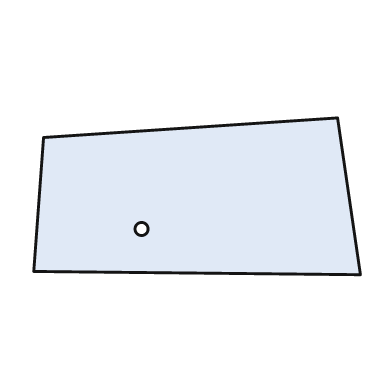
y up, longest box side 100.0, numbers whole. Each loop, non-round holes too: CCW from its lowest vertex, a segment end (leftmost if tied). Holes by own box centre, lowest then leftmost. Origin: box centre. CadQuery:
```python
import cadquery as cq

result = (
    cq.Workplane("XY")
    .moveTo(50.0, -24.0)
    .lineTo(43.0, 24.0)
    .lineTo(-47.0, 18.0)
    .lineTo(-50.0, -23.0)
    .close()
    .moveTo(-17.0, -10.0)
    .circle(2.0)
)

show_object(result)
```